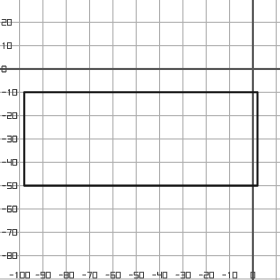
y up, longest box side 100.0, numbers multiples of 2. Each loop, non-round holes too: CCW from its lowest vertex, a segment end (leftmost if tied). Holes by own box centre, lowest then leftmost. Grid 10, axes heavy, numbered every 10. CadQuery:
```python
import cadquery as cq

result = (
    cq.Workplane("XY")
    .moveTo(-98.0, -50.0)
    .lineTo(2.0, -50.0)
    .lineTo(2.0, -10.0)
    .lineTo(-98.0, -10.0)
    .close()
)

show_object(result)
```